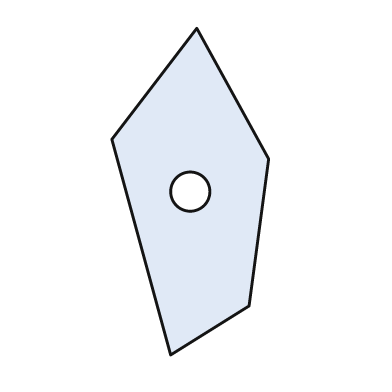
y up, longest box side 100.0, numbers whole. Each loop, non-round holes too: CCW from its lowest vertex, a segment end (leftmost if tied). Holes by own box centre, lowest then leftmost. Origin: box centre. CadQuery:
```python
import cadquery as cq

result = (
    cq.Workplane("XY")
    .moveTo(-6.0, -50.0)
    .lineTo(18.0, -35.0)
    .lineTo(24.0, 10.0)
    .lineTo(2.0, 50.0)
    .lineTo(-24.0, 16.0)
    .close()
    .moveTo(0.0, 0.0)
    .circle(6.0)
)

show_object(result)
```